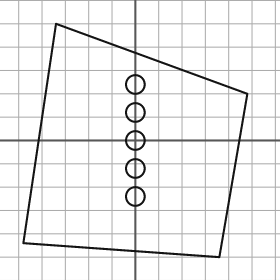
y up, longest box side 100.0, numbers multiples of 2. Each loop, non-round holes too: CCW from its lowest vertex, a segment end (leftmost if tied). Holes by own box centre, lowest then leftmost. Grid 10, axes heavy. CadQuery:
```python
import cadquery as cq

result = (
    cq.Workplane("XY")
    .moveTo(36.0, -50.0)
    .lineTo(48.0, 20.0)
    .lineTo(-34.0, 50.0)
    .lineTo(-48.0, -44.0)
    .close()
    .moveTo(0.0, -24.0)
    .circle(4.0)
    .moveTo(0.0, -12.0)
    .circle(4.0)
    .moveTo(0.0, 0.0)
    .circle(4.0)
    .moveTo(0.0, 12.0)
    .circle(4.0)
    .moveTo(0.0, 24.0)
    .circle(4.0)
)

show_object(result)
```